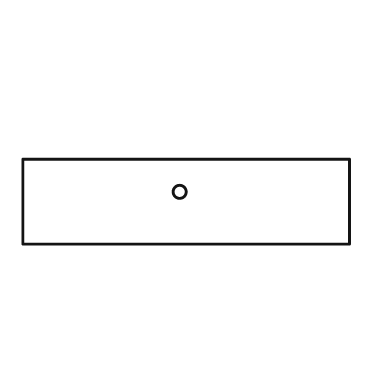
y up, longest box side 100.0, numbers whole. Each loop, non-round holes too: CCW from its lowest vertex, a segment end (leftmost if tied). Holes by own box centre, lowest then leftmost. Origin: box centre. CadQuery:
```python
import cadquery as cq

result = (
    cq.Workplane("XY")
    .moveTo(-50.0, -13.0)
    .lineTo(50.0, -13.0)
    .lineTo(50.0, 13.0)
    .lineTo(-50.0, 13.0)
    .close()
    .moveTo(-2.0, 3.0)
    .circle(2.0)
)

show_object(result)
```